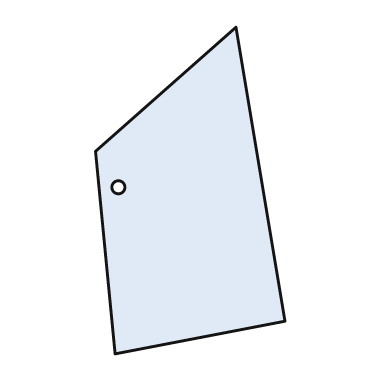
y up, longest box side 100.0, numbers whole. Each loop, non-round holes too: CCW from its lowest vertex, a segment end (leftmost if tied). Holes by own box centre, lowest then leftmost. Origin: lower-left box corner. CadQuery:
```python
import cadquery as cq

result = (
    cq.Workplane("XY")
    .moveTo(6.0, 0.0)
    .lineTo(58.0, 10.0)
    .lineTo(43.0, 100.0)
    .lineTo(0.0, 62.0)
    .close()
    .moveTo(7.0, 51.0)
    .circle(2.0)
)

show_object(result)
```